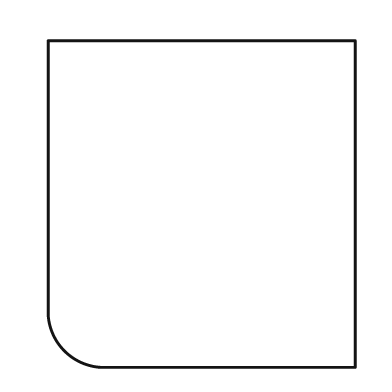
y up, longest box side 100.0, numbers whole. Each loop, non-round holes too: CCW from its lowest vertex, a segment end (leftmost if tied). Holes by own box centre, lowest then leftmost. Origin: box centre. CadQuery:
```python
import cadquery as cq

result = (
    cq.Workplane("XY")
    .moveTo(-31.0, -50.0)
    .lineTo(47.0, -50.0)
    .lineTo(47.0, 50.0)
    .lineTo(-47.0, 50.0)
    .lineTo(-47.0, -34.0)
    .threePointArc((-42.0, -45.0), (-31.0, -50.0))
    .close()
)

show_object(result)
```